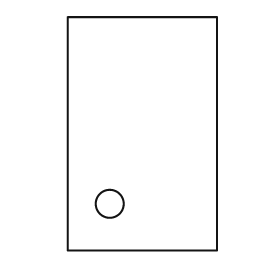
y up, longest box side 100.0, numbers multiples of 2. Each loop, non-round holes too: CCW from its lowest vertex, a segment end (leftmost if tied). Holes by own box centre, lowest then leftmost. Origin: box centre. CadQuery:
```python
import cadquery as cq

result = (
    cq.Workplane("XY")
    .moveTo(-32.0, -50.0)
    .lineTo(32.0, -50.0)
    .lineTo(32.0, 50.0)
    .lineTo(-32.0, 50.0)
    .close()
    .moveTo(-14.0, -30.0)
    .circle(6.0)
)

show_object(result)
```